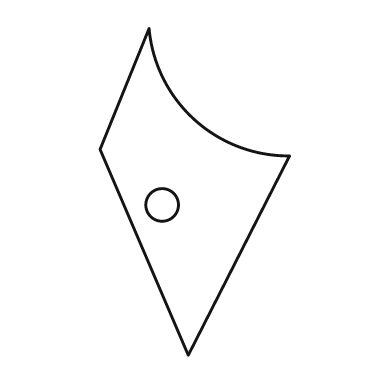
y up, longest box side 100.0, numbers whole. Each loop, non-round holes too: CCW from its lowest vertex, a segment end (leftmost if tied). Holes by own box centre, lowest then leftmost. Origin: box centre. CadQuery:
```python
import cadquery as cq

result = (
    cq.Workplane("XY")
    .moveTo(-2.0, -50.0)
    .lineTo(29.0, 11.0)
    .threePointArc((0.0, 22.0), (-14.0, 50.0))
    .lineTo(-29.0, 13.0)
    .close()
    .moveTo(-10.0, -4.0)
    .circle(5.0)
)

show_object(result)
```